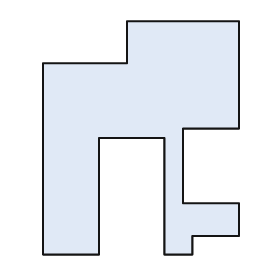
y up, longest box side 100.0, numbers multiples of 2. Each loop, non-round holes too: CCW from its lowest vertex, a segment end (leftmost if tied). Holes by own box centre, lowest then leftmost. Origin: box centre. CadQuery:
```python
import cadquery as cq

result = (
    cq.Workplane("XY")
    .moveTo(-42.0, -50.0)
    .lineTo(-18.0, -50.0)
    .lineTo(-18.0, 0.0)
    .lineTo(10.0, 0.0)
    .lineTo(10.0, -50.0)
    .lineTo(22.0, -50.0)
    .lineTo(22.0, -42.0)
    .lineTo(42.0, -42.0)
    .lineTo(42.0, -28.0)
    .lineTo(18.0, -28.0)
    .lineTo(18.0, 4.0)
    .lineTo(42.0, 4.0)
    .lineTo(42.0, 50.0)
    .lineTo(-6.0, 50.0)
    .lineTo(-6.0, 32.0)
    .lineTo(-42.0, 32.0)
    .close()
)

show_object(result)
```